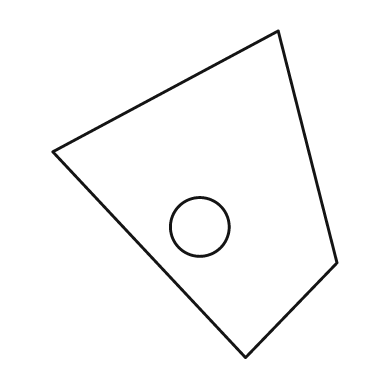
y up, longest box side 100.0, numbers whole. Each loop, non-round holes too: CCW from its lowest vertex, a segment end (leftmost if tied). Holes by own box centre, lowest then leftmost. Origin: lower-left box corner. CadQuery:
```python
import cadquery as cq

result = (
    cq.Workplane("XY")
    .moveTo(59.0, 0.0)
    .lineTo(87.0, 29.0)
    .lineTo(69.0, 100.0)
    .lineTo(0.0, 63.0)
    .close()
    .moveTo(45.0, 40.0)
    .circle(9.0)
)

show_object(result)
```